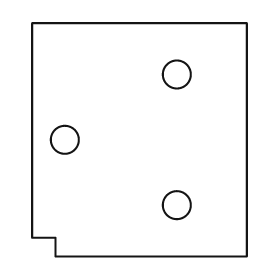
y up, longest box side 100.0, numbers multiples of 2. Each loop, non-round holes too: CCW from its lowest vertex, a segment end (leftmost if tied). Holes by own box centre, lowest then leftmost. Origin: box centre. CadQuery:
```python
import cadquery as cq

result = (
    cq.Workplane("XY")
    .moveTo(-36.0, -50.0)
    .lineTo(46.0, -50.0)
    .lineTo(46.0, 50.0)
    .lineTo(-46.0, 50.0)
    .lineTo(-46.0, -42.0)
    .lineTo(-36.0, -42.0)
    .close()
    .moveTo(16.0, -28.0)
    .circle(6.0)
    .moveTo(-32.0, 0.0)
    .circle(6.0)
    .moveTo(16.0, 28.0)
    .circle(6.0)
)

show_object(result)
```